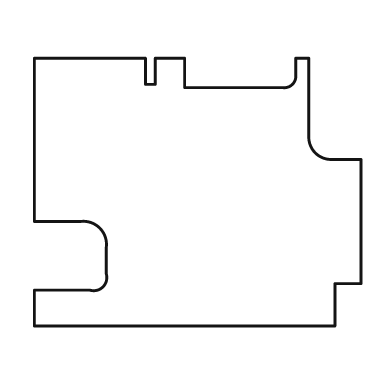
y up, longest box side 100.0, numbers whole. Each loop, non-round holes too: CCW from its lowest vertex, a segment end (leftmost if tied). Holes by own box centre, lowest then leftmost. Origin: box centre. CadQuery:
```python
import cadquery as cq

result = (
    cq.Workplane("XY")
    .moveTo(-50.0, -41.0)
    .lineTo(42.0, -41.0)
    .lineTo(42.0, -28.0)
    .lineTo(50.0, -28.0)
    .lineTo(50.0, 10.0)
    .lineTo(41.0, 10.0)
    .threePointArc((36.0, 12.0), (34.0, 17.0))
    .lineTo(34.0, 41.0)
    .lineTo(30.0, 41.0)
    .lineTo(30.0, 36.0)
    .threePointArc((29.0, 33.0), (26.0, 32.0))
    .lineTo(-4.0, 32.0)
    .lineTo(-4.0, 41.0)
    .lineTo(-13.0, 41.0)
    .lineTo(-13.0, 33.0)
    .lineTo(-16.0, 33.0)
    .lineTo(-16.0, 41.0)
    .lineTo(-50.0, 41.0)
    .lineTo(-50.0, -9.0)
    .lineTo(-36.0, -9.0)
    .threePointArc((-30.0, -11.0), (-28.0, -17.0))
    .lineTo(-28.0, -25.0)
    .threePointArc((-29.0, -29.0), (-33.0, -30.0))
    .lineTo(-50.0, -30.0)
    .close()
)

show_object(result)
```